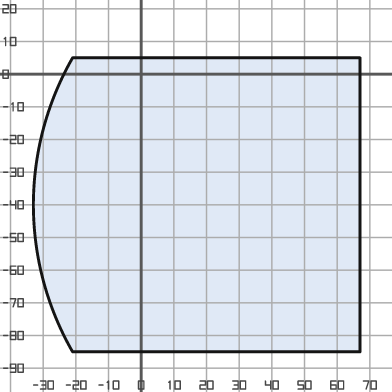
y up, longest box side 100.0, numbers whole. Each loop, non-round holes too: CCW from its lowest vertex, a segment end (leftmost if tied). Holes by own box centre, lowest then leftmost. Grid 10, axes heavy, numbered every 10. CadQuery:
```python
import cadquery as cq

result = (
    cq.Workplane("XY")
    .moveTo(-21.0, -85.0)
    .lineTo(67.0, -85.0)
    .lineTo(67.0, 5.0)
    .lineTo(-21.0, 5.0)
    .threePointArc((-33.0, -40.0), (-21.0, -85.0))
    .close()
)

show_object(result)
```